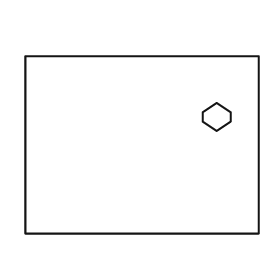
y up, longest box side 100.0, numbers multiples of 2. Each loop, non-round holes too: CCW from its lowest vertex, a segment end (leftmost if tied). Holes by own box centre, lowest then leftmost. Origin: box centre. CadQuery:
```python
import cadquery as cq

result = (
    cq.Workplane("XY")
    .moveTo(-50.0, -38.0)
    .lineTo(50.0, -38.0)
    .lineTo(50.0, 38.0)
    .lineTo(-50.0, 38.0)
    .close()
    .moveTo(32.0, 6.0)
    .lineTo(38.0, 10.0)
    .lineTo(38.0, 14.0)
    .lineTo(32.0, 18.0)
    .lineTo(26.0, 14.0)
    .lineTo(26.0, 10.0)
    .close()
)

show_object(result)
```